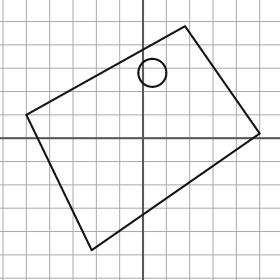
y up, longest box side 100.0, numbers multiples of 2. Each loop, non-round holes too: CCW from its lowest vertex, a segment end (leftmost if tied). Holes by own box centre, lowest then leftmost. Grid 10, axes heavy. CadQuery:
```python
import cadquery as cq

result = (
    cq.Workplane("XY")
    .moveTo(-22.0, -48.0)
    .lineTo(50.0, 2.0)
    .lineTo(18.0, 48.0)
    .lineTo(-50.0, 10.0)
    .close()
    .moveTo(4.0, 28.0)
    .circle(6.0)
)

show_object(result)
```